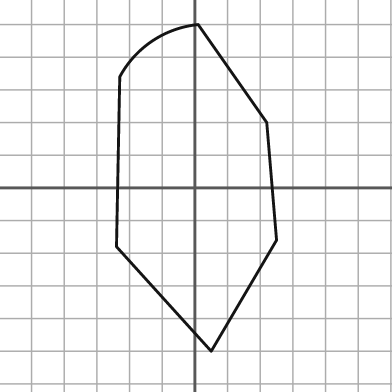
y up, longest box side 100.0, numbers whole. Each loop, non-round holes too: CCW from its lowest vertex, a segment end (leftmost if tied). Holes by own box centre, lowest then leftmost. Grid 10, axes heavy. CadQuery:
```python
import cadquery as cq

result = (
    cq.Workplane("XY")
    .moveTo(5.0, -50.0)
    .lineTo(25.0, -16.0)
    .lineTo(22.0, 20.0)
    .lineTo(1.0, 50.0)
    .threePointArc((-13.0, 45.0), (-23.0, 34.0))
    .lineTo(-24.0, -18.0)
    .close()
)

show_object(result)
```